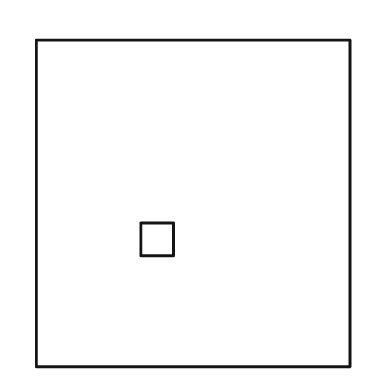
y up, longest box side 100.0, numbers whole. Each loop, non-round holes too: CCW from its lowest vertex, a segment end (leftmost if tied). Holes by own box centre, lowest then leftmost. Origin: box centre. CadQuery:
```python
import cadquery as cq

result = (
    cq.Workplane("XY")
    .moveTo(-48.0, -50.0)
    .lineTo(48.0, -50.0)
    .lineTo(48.0, 50.0)
    .lineTo(-48.0, 50.0)
    .close()
    .moveTo(-16.0, -16.0)
    .lineTo(-6.0, -16.0)
    .lineTo(-6.0, -6.0)
    .lineTo(-16.0, -6.0)
    .close()
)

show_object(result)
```